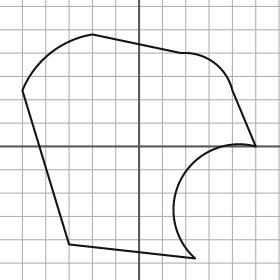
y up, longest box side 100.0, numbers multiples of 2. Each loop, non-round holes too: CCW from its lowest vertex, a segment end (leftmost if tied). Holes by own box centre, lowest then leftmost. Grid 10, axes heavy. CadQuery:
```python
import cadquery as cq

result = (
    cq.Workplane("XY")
    .moveTo(24.0, -48.0)
    .threePointArc((18.0, -14.0), (50.0, 0.0))
    .lineTo(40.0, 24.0)
    .threePointArc((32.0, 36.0), (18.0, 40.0))
    .lineTo(-20.0, 48.0)
    .threePointArc((-38.0, 40.0), (-50.0, 24.0))
    .lineTo(-30.0, -42.0)
    .close()
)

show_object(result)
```